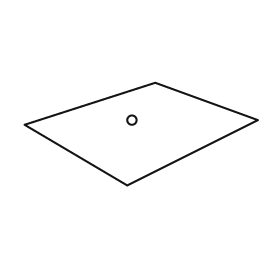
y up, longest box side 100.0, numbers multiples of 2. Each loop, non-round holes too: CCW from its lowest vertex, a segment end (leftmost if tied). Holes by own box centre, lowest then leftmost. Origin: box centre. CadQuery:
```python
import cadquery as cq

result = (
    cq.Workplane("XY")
    .moveTo(-6.0, -22.0)
    .lineTo(50.0, 6.0)
    .lineTo(6.0, 22.0)
    .lineTo(-50.0, 4.0)
    .close()
    .moveTo(-4.0, 6.0)
    .circle(2.0)
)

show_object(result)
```